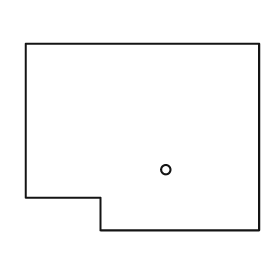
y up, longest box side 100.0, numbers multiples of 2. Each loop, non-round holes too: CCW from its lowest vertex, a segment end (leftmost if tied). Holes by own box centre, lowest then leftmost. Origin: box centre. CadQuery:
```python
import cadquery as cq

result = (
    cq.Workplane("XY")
    .moveTo(-18.0, -40.0)
    .lineTo(50.0, -40.0)
    .lineTo(50.0, 40.0)
    .lineTo(-50.0, 40.0)
    .lineTo(-50.0, -26.0)
    .lineTo(-18.0, -26.0)
    .close()
    .moveTo(10.0, -14.0)
    .circle(2.0)
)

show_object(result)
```